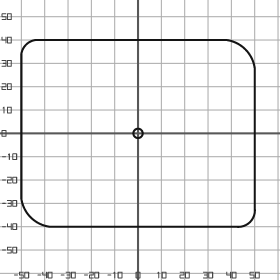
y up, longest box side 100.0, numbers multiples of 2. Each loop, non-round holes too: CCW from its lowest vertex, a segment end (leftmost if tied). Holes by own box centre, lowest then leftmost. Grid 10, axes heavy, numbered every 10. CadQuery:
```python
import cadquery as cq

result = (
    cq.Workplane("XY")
    .moveTo(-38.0, -40.0)
    .lineTo(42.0, -40.0)
    .threePointArc((48.0, -38.0), (50.0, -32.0))
    .lineTo(50.0, 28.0)
    .threePointArc((46.0, 36.0), (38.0, 40.0))
    .lineTo(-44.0, 40.0)
    .threePointArc((-48.0, 38.0), (-50.0, 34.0))
    .lineTo(-50.0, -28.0)
    .threePointArc((-46.0, -36.0), (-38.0, -40.0))
    .close()
    .moveTo(0.0, 0.0)
    .circle(2.0)
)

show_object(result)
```